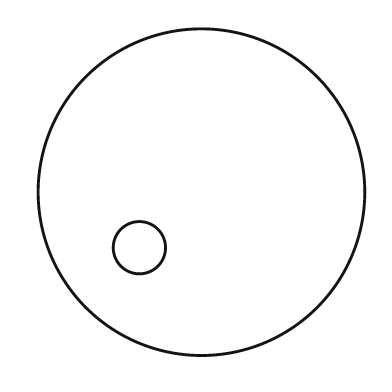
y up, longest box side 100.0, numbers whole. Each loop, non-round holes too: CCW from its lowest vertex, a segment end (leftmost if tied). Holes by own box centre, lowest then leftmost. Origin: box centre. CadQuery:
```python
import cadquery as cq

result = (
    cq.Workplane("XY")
    .moveTo(0.0, 0.0)
    .circle(50.0)
    .moveTo(-19.0, -17.0)
    .circle(8.0)
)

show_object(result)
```